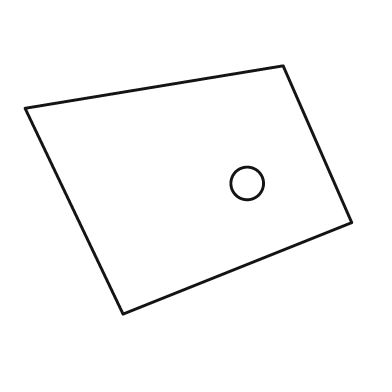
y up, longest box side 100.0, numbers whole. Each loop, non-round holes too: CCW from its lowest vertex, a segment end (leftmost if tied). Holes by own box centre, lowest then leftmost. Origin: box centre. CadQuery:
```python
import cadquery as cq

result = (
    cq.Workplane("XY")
    .moveTo(-20.0, -38.0)
    .lineTo(50.0, -10.0)
    .lineTo(29.0, 38.0)
    .lineTo(-50.0, 25.0)
    .close()
    .moveTo(18.0, 2.0)
    .circle(5.0)
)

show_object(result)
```